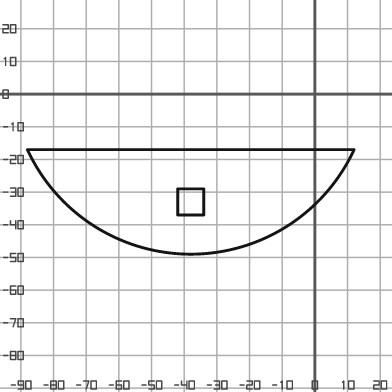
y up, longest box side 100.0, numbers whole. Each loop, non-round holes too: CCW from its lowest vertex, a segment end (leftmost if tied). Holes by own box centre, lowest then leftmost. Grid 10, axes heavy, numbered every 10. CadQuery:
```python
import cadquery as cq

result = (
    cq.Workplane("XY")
    .moveTo(-88.0, -17.0)
    .threePointArc((-38.0, -49.0), (12.0, -17.0))
    .close()
    .moveTo(-42.0, -37.0)
    .lineTo(-34.0, -37.0)
    .lineTo(-34.0, -29.0)
    .lineTo(-42.0, -29.0)
    .close()
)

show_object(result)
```